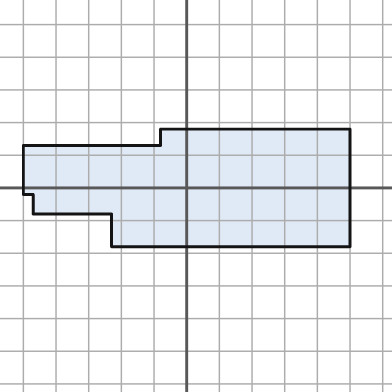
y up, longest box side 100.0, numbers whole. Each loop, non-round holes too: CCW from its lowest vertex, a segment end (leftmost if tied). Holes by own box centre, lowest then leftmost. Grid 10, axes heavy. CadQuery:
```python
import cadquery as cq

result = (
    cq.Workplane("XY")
    .moveTo(-23.0, -18.0)
    .lineTo(50.0, -18.0)
    .lineTo(50.0, 18.0)
    .lineTo(-8.0, 18.0)
    .lineTo(-8.0, 13.0)
    .lineTo(-50.0, 13.0)
    .lineTo(-50.0, -2.0)
    .lineTo(-47.0, -2.0)
    .lineTo(-47.0, -8.0)
    .lineTo(-23.0, -8.0)
    .close()
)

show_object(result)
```